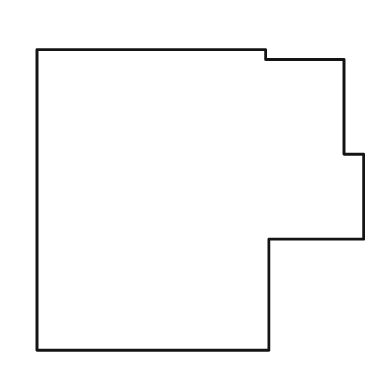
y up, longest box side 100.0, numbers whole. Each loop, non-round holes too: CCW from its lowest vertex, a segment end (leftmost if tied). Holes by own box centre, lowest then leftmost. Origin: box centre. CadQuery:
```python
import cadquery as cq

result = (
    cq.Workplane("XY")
    .moveTo(-50.0, -46.0)
    .lineTo(21.0, -46.0)
    .lineTo(21.0, -12.0)
    .lineTo(50.0, -12.0)
    .lineTo(50.0, 14.0)
    .lineTo(44.0, 14.0)
    .lineTo(44.0, 43.0)
    .lineTo(20.0, 43.0)
    .lineTo(20.0, 46.0)
    .lineTo(-50.0, 46.0)
    .close()
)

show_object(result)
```